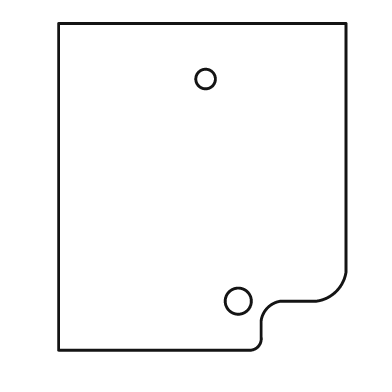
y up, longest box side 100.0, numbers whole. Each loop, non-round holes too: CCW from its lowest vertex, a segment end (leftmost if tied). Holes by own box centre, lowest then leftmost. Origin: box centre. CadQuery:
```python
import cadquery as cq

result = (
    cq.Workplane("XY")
    .moveTo(-44.0, -50.0)
    .lineTo(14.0, -50.0)
    .threePointArc((17.0, -49.0), (18.0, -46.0))
    .lineTo(18.0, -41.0)
    .threePointArc((20.0, -37.0), (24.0, -35.0))
    .lineTo(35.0, -35.0)
    .threePointArc((41.0, -32.0), (44.0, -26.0))
    .lineTo(44.0, 50.0)
    .lineTo(-44.0, 50.0)
    .close()
    .moveTo(11.0, -35.0)
    .circle(4.0)
    .moveTo(1.0, 33.0)
    .circle(3.0)
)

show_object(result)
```